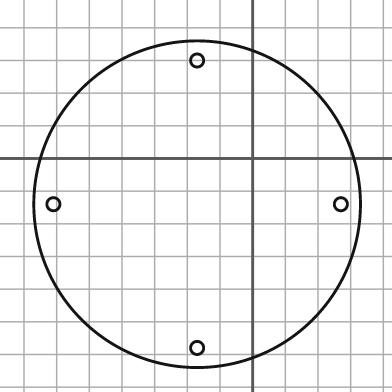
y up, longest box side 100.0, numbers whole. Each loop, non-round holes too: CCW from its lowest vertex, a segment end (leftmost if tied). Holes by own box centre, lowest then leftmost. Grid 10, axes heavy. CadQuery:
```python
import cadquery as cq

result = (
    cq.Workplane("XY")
    .moveTo(-17.0, -14.0)
    .circle(50.0)
    .moveTo(-17.0, -58.0)
    .circle(2.0)
    .moveTo(-61.0, -14.0)
    .circle(2.0)
    .moveTo(27.0, -14.0)
    .circle(2.0)
    .moveTo(-17.0, 30.0)
    .circle(2.0)
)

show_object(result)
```